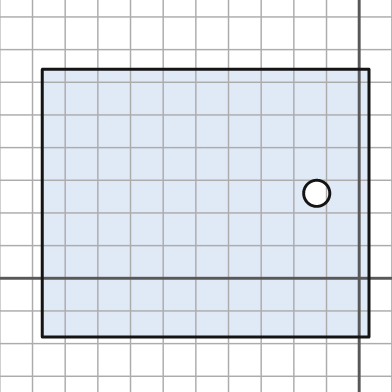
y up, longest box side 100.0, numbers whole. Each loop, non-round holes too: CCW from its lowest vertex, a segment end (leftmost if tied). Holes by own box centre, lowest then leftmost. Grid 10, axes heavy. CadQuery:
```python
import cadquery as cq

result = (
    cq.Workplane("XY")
    .moveTo(-97.0, -18.0)
    .lineTo(3.0, -18.0)
    .lineTo(3.0, 64.0)
    .lineTo(-97.0, 64.0)
    .close()
    .moveTo(-13.0, 26.0)
    .circle(4.0)
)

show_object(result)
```